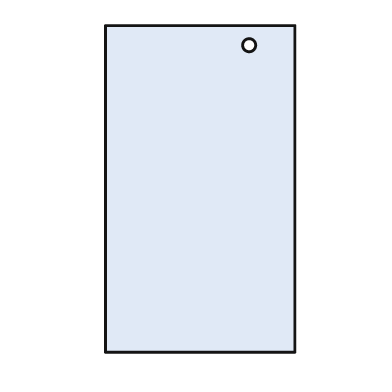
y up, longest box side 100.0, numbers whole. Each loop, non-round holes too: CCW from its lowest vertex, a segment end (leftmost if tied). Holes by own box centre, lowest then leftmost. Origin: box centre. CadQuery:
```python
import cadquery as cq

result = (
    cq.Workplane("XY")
    .moveTo(-29.0, -50.0)
    .lineTo(29.0, -50.0)
    .lineTo(29.0, 50.0)
    .lineTo(-29.0, 50.0)
    .close()
    .moveTo(15.0, 44.0)
    .circle(2.0)
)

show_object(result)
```